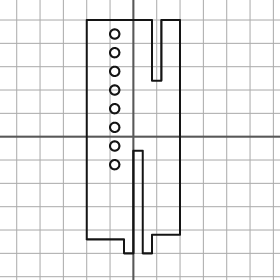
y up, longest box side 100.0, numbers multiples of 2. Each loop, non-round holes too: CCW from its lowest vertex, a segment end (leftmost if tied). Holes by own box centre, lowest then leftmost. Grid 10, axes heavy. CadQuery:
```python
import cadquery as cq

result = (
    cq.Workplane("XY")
    .moveTo(-4.0, -50.0)
    .lineTo(0.0, -50.0)
    .lineTo(0.0, -6.0)
    .lineTo(4.0, -6.0)
    .lineTo(4.0, -50.0)
    .lineTo(8.0, -50.0)
    .lineTo(8.0, -42.0)
    .lineTo(20.0, -42.0)
    .lineTo(20.0, 50.0)
    .lineTo(12.0, 50.0)
    .lineTo(12.0, 24.0)
    .lineTo(8.0, 24.0)
    .lineTo(8.0, 50.0)
    .lineTo(-20.0, 50.0)
    .lineTo(-20.0, -44.0)
    .lineTo(-4.0, -44.0)
    .close()
    .moveTo(-8.0, -12.0)
    .circle(2.0)
    .moveTo(-8.0, -4.0)
    .circle(2.0)
    .moveTo(-8.0, 4.0)
    .circle(2.0)
    .moveTo(-8.0, 12.0)
    .circle(2.0)
    .moveTo(-8.0, 20.0)
    .circle(2.0)
    .moveTo(-8.0, 28.0)
    .circle(2.0)
    .moveTo(-8.0, 36.0)
    .circle(2.0)
    .moveTo(-8.0, 44.0)
    .circle(2.0)
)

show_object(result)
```